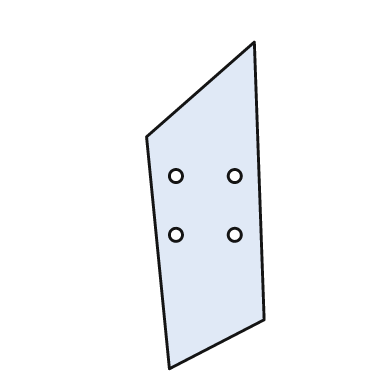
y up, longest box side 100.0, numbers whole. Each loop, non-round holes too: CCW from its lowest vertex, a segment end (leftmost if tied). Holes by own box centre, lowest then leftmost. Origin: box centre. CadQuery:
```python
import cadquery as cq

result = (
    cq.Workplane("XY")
    .moveTo(-11.0, -50.0)
    .lineTo(18.0, -35.0)
    .lineTo(15.0, 50.0)
    .lineTo(-18.0, 21.0)
    .close()
    .moveTo(-9.0, -9.0)
    .circle(2.0)
    .moveTo(9.0, -9.0)
    .circle(2.0)
    .moveTo(-9.0, 9.0)
    .circle(2.0)
    .moveTo(9.0, 9.0)
    .circle(2.0)
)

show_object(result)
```